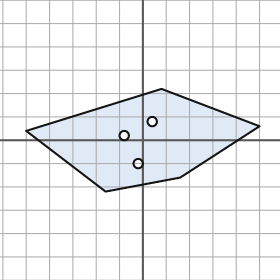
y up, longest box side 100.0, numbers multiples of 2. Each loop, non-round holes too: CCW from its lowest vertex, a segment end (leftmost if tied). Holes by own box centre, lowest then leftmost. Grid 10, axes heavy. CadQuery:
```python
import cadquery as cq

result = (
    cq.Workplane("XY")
    .moveTo(-16.0, -22.0)
    .lineTo(16.0, -16.0)
    .lineTo(50.0, 6.0)
    .lineTo(8.0, 22.0)
    .lineTo(-50.0, 4.0)
    .close()
    .moveTo(-2.0, -10.0)
    .circle(2.0)
    .moveTo(-8.0, 2.0)
    .circle(2.0)
    .moveTo(4.0, 8.0)
    .circle(2.0)
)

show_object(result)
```